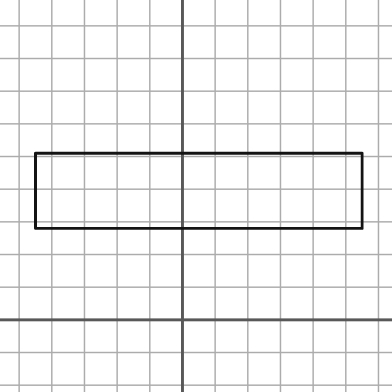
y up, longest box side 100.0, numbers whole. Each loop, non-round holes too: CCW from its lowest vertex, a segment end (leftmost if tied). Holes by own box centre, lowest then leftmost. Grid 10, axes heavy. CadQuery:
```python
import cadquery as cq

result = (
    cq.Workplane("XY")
    .moveTo(-45.0, 28.0)
    .lineTo(55.0, 28.0)
    .lineTo(55.0, 51.0)
    .lineTo(-45.0, 51.0)
    .close()
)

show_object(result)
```